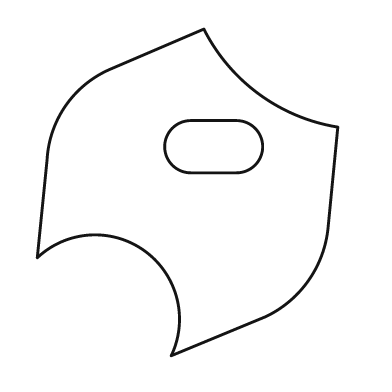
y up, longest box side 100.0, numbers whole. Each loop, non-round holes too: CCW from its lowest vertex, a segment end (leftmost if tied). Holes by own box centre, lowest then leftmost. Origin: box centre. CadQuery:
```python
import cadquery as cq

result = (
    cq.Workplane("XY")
    .moveTo(-5.0, -50.0)
    .lineTo(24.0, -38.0)
    .threePointArc((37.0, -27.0), (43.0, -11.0))
    .lineTo(46.0, 20.0)
    .threePointArc((22.0, 30.0), (5.0, 50.0))
    .lineTo(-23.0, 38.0)
    .threePointArc((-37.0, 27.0), (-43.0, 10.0))
    .lineTo(-46.0, -20.0)
    .threePointArc((-13.0, -18.0), (-5.0, -50.0))
    .close()
    .moveTo(1.0, 6.0)
    .lineTo(15.0, 6.0)
    .threePointArc((23.0, 14.0), (15.0, 22.0))
    .lineTo(1.0, 22.0)
    .threePointArc((-7.0, 14.0), (1.0, 6.0))
    .close()
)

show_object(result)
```